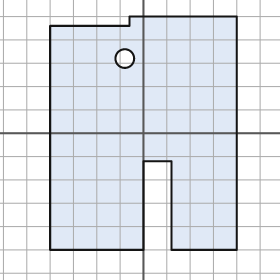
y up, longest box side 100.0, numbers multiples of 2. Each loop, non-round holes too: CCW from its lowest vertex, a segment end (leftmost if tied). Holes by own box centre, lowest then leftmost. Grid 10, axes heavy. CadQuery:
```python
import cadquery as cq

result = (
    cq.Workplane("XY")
    .moveTo(-40.0, -50.0)
    .lineTo(0.0, -50.0)
    .lineTo(0.0, -12.0)
    .lineTo(12.0, -12.0)
    .lineTo(12.0, -50.0)
    .lineTo(40.0, -50.0)
    .lineTo(40.0, 50.0)
    .lineTo(-6.0, 50.0)
    .lineTo(-6.0, 46.0)
    .lineTo(-40.0, 46.0)
    .close()
    .moveTo(-8.0, 32.0)
    .circle(4.0)
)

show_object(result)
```